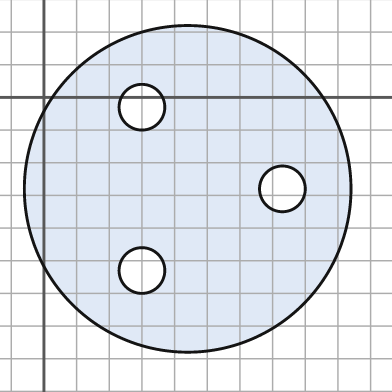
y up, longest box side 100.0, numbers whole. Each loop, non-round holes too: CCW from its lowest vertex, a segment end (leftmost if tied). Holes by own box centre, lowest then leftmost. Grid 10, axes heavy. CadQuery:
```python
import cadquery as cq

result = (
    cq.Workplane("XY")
    .moveTo(44.0, -28.0)
    .circle(50.0)
    .moveTo(30.0, -53.0)
    .circle(7.0)
    .moveTo(73.0, -28.0)
    .circle(7.0)
    .moveTo(30.0, -3.0)
    .circle(7.0)
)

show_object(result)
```